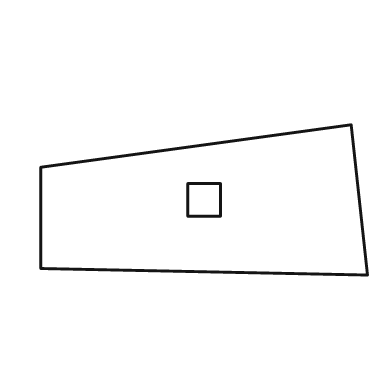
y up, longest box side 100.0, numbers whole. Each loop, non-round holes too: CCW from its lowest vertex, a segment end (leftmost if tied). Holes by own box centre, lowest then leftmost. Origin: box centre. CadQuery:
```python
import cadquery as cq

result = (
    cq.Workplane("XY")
    .moveTo(50.0, -23.0)
    .lineTo(45.0, 23.0)
    .lineTo(-50.0, 10.0)
    .lineTo(-50.0, -21.0)
    .close()
    .moveTo(-5.0, -5.0)
    .lineTo(5.0, -5.0)
    .lineTo(5.0, 5.0)
    .lineTo(-5.0, 5.0)
    .close()
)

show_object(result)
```